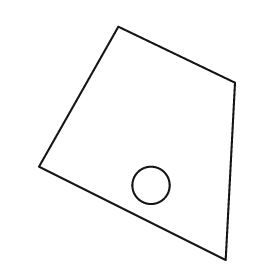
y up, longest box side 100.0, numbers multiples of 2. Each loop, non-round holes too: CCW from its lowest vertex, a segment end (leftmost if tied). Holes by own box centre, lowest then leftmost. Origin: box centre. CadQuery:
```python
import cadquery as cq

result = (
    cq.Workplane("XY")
    .moveTo(38.0, -50.0)
    .lineTo(42.0, 26.0)
    .lineTo(-8.0, 50.0)
    .lineTo(-42.0, -10.0)
    .close()
    .moveTo(6.0, -18.0)
    .circle(8.0)
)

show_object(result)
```